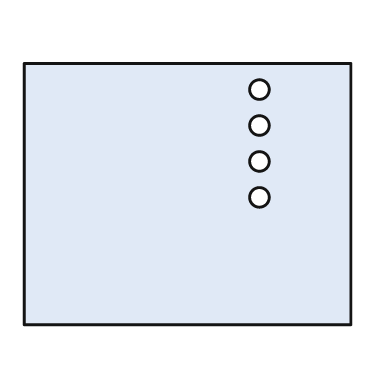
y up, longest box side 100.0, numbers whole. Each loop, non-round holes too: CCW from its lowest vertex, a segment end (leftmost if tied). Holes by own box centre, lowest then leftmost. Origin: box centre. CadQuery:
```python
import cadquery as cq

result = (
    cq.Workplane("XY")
    .moveTo(-50.0, -40.0)
    .lineTo(50.0, -40.0)
    .lineTo(50.0, 40.0)
    .lineTo(-50.0, 40.0)
    .close()
    .moveTo(22.0, -1.0)
    .circle(3.0)
    .moveTo(22.0, 10.0)
    .circle(3.0)
    .moveTo(22.0, 21.0)
    .circle(3.0)
    .moveTo(22.0, 32.0)
    .circle(3.0)
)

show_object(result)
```